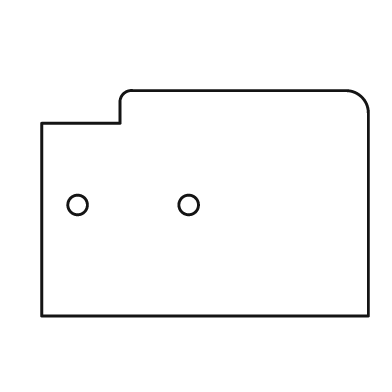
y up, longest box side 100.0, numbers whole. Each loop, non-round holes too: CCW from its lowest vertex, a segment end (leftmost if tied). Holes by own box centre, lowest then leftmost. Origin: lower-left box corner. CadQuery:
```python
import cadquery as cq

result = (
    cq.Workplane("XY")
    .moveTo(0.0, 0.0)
    .lineTo(100.0, 0.0)
    .lineTo(100.0, 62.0)
    .threePointArc((98.0, 67.0), (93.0, 69.0))
    .lineTo(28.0, 69.0)
    .threePointArc((25.0, 68.0), (24.0, 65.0))
    .lineTo(24.0, 59.0)
    .lineTo(0.0, 59.0)
    .close()
    .moveTo(11.0, 34.0)
    .circle(3.0)
    .moveTo(45.0, 34.0)
    .circle(3.0)
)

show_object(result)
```